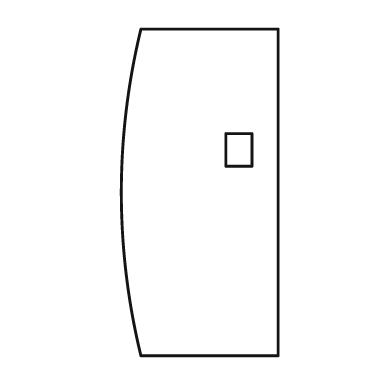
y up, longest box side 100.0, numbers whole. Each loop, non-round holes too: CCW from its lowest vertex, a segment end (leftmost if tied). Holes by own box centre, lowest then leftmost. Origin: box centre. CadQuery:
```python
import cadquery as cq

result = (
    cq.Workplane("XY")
    .moveTo(-18.0, -50.0)
    .lineTo(24.0, -50.0)
    .lineTo(24.0, 50.0)
    .lineTo(-18.0, 50.0)
    .threePointArc((-24.0, 0.0), (-18.0, -50.0))
    .close()
    .moveTo(8.0, 8.0)
    .lineTo(16.0, 8.0)
    .lineTo(16.0, 18.0)
    .lineTo(8.0, 18.0)
    .close()
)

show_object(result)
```